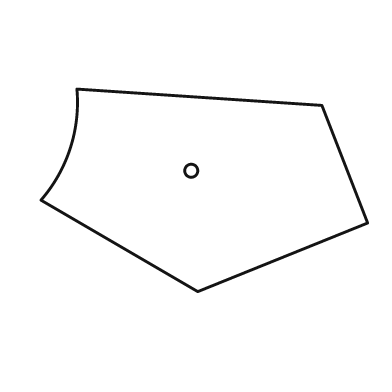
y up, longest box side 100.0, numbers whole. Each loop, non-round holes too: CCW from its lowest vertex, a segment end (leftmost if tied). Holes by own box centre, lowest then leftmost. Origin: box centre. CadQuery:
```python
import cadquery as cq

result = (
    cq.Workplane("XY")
    .moveTo(-2.0, -31.0)
    .lineTo(50.0, -10.0)
    .lineTo(36.0, 26.0)
    .lineTo(-39.0, 31.0)
    .threePointArc((-41.0, 13.0), (-50.0, -3.0))
    .close()
    .moveTo(-4.0, 6.0)
    .circle(2.0)
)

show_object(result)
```